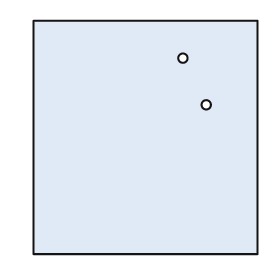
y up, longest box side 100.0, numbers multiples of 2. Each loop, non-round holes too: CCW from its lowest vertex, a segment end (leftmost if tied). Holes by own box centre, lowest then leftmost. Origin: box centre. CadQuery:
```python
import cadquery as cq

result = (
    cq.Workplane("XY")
    .moveTo(-48.0, -50.0)
    .lineTo(48.0, -50.0)
    .lineTo(48.0, 50.0)
    .lineTo(-48.0, 50.0)
    .close()
    .moveTo(26.0, 14.0)
    .circle(2.0)
    .moveTo(16.0, 34.0)
    .circle(2.0)
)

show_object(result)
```